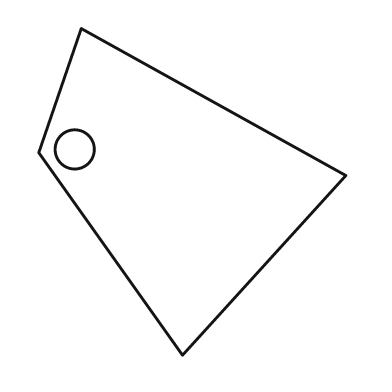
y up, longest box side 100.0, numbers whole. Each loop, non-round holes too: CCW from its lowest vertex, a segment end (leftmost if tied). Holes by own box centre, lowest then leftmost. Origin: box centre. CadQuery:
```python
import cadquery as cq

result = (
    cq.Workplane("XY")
    .moveTo(-3.0, -50.0)
    .lineTo(47.0, 5.0)
    .lineTo(-34.0, 50.0)
    .lineTo(-47.0, 12.0)
    .close()
    .moveTo(-36.0, 13.0)
    .circle(6.0)
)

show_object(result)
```